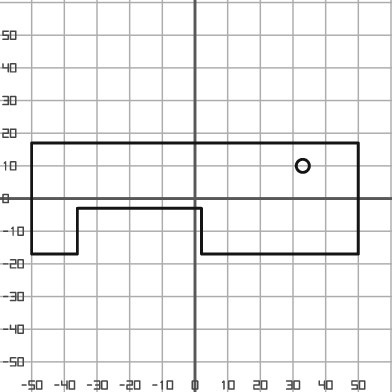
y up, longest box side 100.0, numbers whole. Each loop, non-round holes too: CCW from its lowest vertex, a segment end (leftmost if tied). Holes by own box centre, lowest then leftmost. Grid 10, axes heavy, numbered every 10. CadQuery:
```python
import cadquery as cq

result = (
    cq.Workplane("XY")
    .moveTo(-50.0, -17.0)
    .lineTo(-36.0, -17.0)
    .lineTo(-36.0, -3.0)
    .lineTo(2.0, -3.0)
    .lineTo(2.0, -17.0)
    .lineTo(50.0, -17.0)
    .lineTo(50.0, 17.0)
    .lineTo(-50.0, 17.0)
    .close()
    .moveTo(33.0, 10.0)
    .circle(2.0)
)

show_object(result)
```